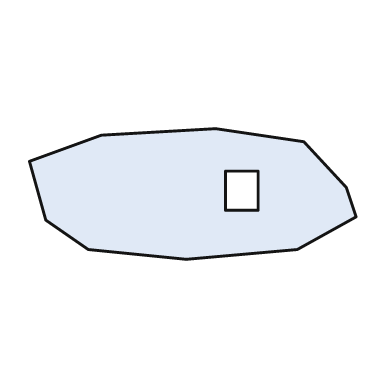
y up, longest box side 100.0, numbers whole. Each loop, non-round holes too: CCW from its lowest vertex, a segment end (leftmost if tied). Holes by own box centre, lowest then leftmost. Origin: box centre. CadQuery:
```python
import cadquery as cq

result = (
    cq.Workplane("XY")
    .moveTo(-2.0, -20.0)
    .lineTo(32.0, -17.0)
    .lineTo(50.0, -7.0)
    .lineTo(47.0, 2.0)
    .lineTo(34.0, 16.0)
    .lineTo(7.0, 20.0)
    .lineTo(-28.0, 18.0)
    .lineTo(-50.0, 10.0)
    .lineTo(-45.0, -8.0)
    .lineTo(-32.0, -17.0)
    .close()
    .moveTo(10.0, -5.0)
    .lineTo(20.0, -5.0)
    .lineTo(20.0, 7.0)
    .lineTo(10.0, 7.0)
    .close()
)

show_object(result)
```